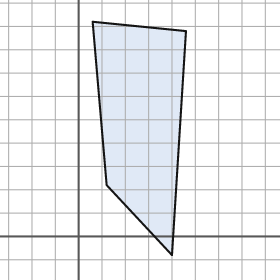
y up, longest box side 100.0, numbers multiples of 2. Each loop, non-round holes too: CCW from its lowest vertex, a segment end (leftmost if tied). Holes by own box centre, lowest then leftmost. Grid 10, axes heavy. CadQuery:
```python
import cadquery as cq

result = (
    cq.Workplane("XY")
    .moveTo(40.0, -8.0)
    .lineTo(46.0, 88.0)
    .lineTo(6.0, 92.0)
    .lineTo(12.0, 22.0)
    .close()
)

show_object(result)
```